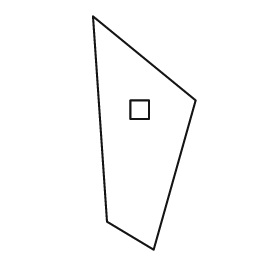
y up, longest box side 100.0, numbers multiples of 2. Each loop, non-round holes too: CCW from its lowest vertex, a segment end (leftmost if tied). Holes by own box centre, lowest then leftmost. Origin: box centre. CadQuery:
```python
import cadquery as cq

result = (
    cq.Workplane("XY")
    .moveTo(4.0, -50.0)
    .lineTo(22.0, 14.0)
    .lineTo(-22.0, 50.0)
    .lineTo(-16.0, -38.0)
    .close()
    .moveTo(-6.0, 6.0)
    .lineTo(2.0, 6.0)
    .lineTo(2.0, 14.0)
    .lineTo(-6.0, 14.0)
    .close()
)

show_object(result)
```